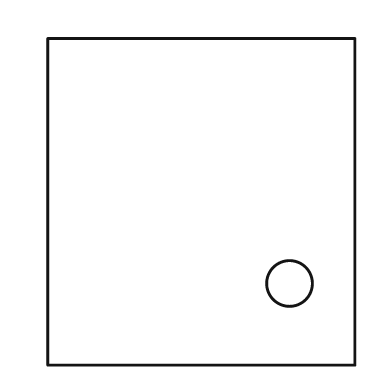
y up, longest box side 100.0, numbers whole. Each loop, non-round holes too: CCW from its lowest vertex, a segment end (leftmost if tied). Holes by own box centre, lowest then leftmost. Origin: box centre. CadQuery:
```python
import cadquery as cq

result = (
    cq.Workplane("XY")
    .moveTo(-47.0, -50.0)
    .lineTo(47.0, -50.0)
    .lineTo(47.0, 50.0)
    .lineTo(-47.0, 50.0)
    .close()
    .moveTo(27.0, -25.0)
    .circle(7.0)
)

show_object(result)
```